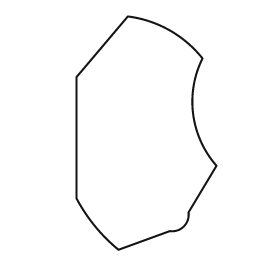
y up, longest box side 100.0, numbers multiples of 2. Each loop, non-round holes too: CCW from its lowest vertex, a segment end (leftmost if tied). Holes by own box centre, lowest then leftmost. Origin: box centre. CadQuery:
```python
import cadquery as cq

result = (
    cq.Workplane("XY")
    .moveTo(-12.0, -50.0)
    .lineTo(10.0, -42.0)
    .threePointArc((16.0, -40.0), (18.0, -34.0))
    .lineTo(30.0, -14.0)
    .threePointArc((20.0, 8.0), (24.0, 32.0))
    .threePointArc((10.0, 44.0), (-8.0, 50.0))
    .lineTo(-30.0, 24.0)
    .lineTo(-30.0, -28.0)
    .threePointArc((-22.0, -40.0), (-12.0, -50.0))
    .close()
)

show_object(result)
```